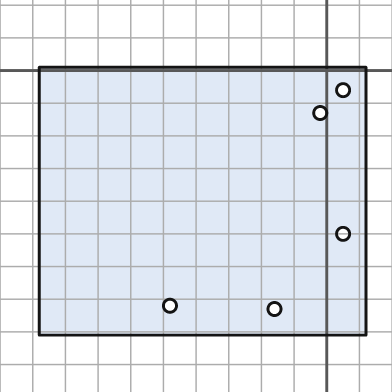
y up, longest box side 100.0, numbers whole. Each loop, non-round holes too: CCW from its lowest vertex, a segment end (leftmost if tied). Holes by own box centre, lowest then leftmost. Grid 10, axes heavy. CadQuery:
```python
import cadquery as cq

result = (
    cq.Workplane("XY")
    .moveTo(-88.0, -81.0)
    .lineTo(12.0, -81.0)
    .lineTo(12.0, 1.0)
    .lineTo(-88.0, 1.0)
    .close()
    .moveTo(-16.0, -73.0)
    .circle(2.0)
    .moveTo(-48.0, -72.0)
    .circle(2.0)
    .moveTo(5.0, -50.0)
    .circle(2.0)
    .moveTo(-2.0, -13.0)
    .circle(2.0)
    .moveTo(5.0, -6.0)
    .circle(2.0)
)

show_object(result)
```